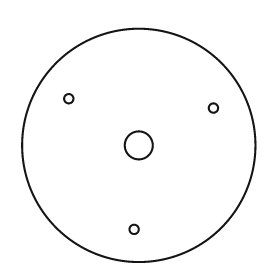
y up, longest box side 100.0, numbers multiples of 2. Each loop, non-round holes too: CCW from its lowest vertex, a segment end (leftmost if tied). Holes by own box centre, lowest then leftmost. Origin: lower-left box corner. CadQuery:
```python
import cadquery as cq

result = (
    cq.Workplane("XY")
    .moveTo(50.0, 50.0)
    .circle(50.0)
    .moveTo(48.0, 14.0)
    .circle(2.0)
    .moveTo(50.0, 50.0)
    .circle(6.0)
    .moveTo(82.0, 66.0)
    .circle(2.0)
    .moveTo(20.0, 70.0)
    .circle(2.0)
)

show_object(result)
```